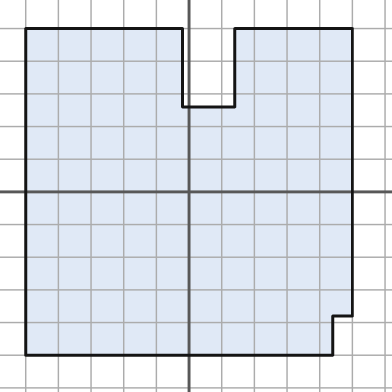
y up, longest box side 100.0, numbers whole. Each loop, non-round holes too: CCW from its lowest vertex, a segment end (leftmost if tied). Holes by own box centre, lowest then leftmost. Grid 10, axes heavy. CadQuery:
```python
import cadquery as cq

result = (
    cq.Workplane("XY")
    .moveTo(-50.0, -50.0)
    .lineTo(44.0, -50.0)
    .lineTo(44.0, -38.0)
    .lineTo(50.0, -38.0)
    .lineTo(50.0, 50.0)
    .lineTo(14.0, 50.0)
    .lineTo(14.0, 26.0)
    .lineTo(-2.0, 26.0)
    .lineTo(-2.0, 50.0)
    .lineTo(-50.0, 50.0)
    .close()
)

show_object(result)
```